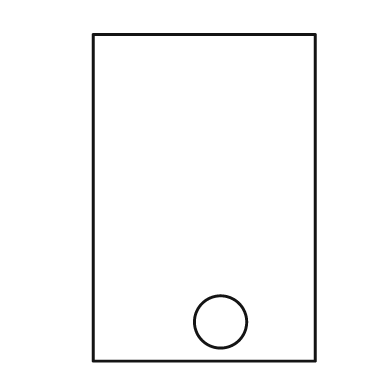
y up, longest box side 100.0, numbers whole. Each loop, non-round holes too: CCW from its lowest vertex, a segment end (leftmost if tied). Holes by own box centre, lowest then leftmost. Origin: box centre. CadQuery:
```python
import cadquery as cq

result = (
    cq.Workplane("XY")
    .moveTo(-34.0, -50.0)
    .lineTo(34.0, -50.0)
    .lineTo(34.0, 50.0)
    .lineTo(-34.0, 50.0)
    .close()
    .moveTo(5.0, -38.0)
    .circle(8.0)
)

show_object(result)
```